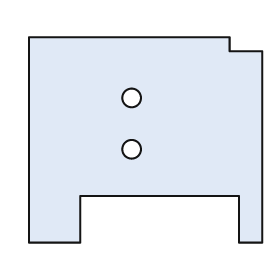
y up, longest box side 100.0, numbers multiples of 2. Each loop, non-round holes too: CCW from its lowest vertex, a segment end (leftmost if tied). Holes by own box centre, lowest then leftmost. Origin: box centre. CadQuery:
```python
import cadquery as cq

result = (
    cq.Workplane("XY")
    .moveTo(-50.0, -44.0)
    .lineTo(-28.0, -44.0)
    .lineTo(-28.0, -24.0)
    .lineTo(40.0, -24.0)
    .lineTo(40.0, -44.0)
    .lineTo(50.0, -44.0)
    .lineTo(50.0, 38.0)
    .lineTo(36.0, 38.0)
    .lineTo(36.0, 44.0)
    .lineTo(-50.0, 44.0)
    .close()
    .moveTo(-6.0, -4.0)
    .circle(4.0)
    .moveTo(-6.0, 18.0)
    .circle(4.0)
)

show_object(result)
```